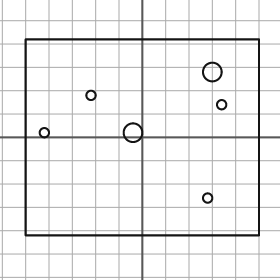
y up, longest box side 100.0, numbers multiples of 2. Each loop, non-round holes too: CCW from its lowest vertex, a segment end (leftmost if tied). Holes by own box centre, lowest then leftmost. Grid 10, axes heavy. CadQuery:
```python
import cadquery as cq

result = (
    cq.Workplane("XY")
    .moveTo(-50.0, -42.0)
    .lineTo(50.0, -42.0)
    .lineTo(50.0, 42.0)
    .lineTo(-50.0, 42.0)
    .close()
    .moveTo(28.0, -26.0)
    .circle(2.0)
    .moveTo(-42.0, 2.0)
    .circle(2.0)
    .moveTo(-4.0, 2.0)
    .circle(4.0)
    .moveTo(34.0, 14.0)
    .circle(2.0)
    .moveTo(-22.0, 18.0)
    .circle(2.0)
    .moveTo(30.0, 28.0)
    .circle(4.0)
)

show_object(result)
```